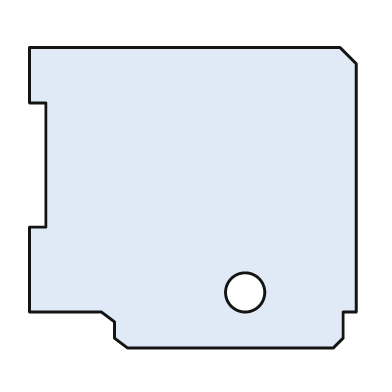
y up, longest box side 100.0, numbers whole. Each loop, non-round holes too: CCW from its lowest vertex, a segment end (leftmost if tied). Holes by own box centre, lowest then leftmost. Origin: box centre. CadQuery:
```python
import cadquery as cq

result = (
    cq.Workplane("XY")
    .moveTo(-20.0, -46.0)
    .lineTo(43.0, -46.0)
    .lineTo(46.0, -43.0)
    .lineTo(46.0, -35.0)
    .lineTo(50.0, -35.0)
    .lineTo(50.0, 41.0)
    .lineTo(45.0, 46.0)
    .lineTo(-50.0, 46.0)
    .lineTo(-50.0, 29.0)
    .lineTo(-45.0, 29.0)
    .lineTo(-45.0, -9.0)
    .lineTo(-50.0, -9.0)
    .lineTo(-50.0, -35.0)
    .lineTo(-28.0, -35.0)
    .lineTo(-24.0, -38.0)
    .lineTo(-24.0, -43.0)
    .close()
    .moveTo(16.0, -29.0)
    .circle(6.0)
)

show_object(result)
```